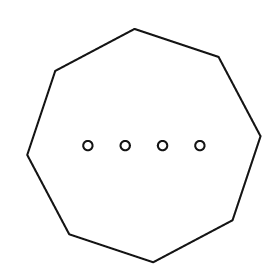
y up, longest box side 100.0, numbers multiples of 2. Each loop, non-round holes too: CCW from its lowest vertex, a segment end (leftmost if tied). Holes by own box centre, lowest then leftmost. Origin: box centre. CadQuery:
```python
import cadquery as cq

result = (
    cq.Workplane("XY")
    .moveTo(4.0, -50.0)
    .lineTo(38.0, -32.0)
    .lineTo(50.0, 4.0)
    .lineTo(32.0, 38.0)
    .lineTo(-4.0, 50.0)
    .lineTo(-38.0, 32.0)
    .lineTo(-50.0, -4.0)
    .lineTo(-32.0, -38.0)
    .close()
    .moveTo(-24.0, 0.0)
    .circle(2.0)
    .moveTo(-8.0, 0.0)
    .circle(2.0)
    .moveTo(8.0, 0.0)
    .circle(2.0)
    .moveTo(24.0, 0.0)
    .circle(2.0)
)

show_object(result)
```